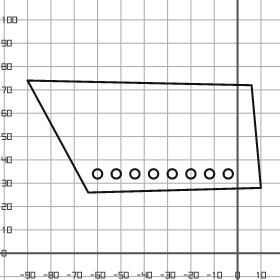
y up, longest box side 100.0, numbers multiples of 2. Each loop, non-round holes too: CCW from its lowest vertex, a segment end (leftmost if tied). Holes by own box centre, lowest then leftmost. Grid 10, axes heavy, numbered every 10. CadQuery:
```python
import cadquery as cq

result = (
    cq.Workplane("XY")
    .moveTo(-64.0, 26.0)
    .lineTo(10.0, 28.0)
    .lineTo(6.0, 72.0)
    .lineTo(-90.0, 74.0)
    .close()
    .moveTo(-60.0, 34.0)
    .circle(2.0)
    .moveTo(-52.0, 34.0)
    .circle(2.0)
    .moveTo(-44.0, 34.0)
    .circle(2.0)
    .moveTo(-36.0, 34.0)
    .circle(2.0)
    .moveTo(-28.0, 34.0)
    .circle(2.0)
    .moveTo(-20.0, 34.0)
    .circle(2.0)
    .moveTo(-12.0, 34.0)
    .circle(2.0)
    .moveTo(-4.0, 34.0)
    .circle(2.0)
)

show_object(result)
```